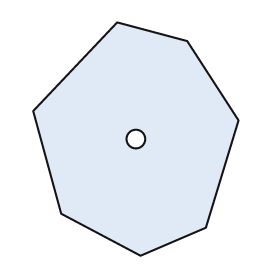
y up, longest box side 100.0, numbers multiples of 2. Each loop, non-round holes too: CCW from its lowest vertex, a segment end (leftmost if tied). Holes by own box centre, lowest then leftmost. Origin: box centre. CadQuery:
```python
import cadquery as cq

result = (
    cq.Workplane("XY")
    .moveTo(2.0, -50.0)
    .lineTo(30.0, -38.0)
    .lineTo(44.0, 8.0)
    .lineTo(22.0, 42.0)
    .lineTo(-8.0, 50.0)
    .lineTo(-44.0, 12.0)
    .lineTo(-32.0, -32.0)
    .close()
    .moveTo(0.0, 0.0)
    .circle(4.0)
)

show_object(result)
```